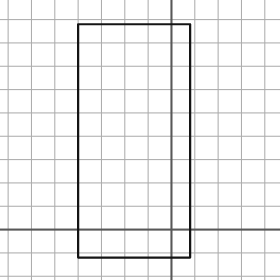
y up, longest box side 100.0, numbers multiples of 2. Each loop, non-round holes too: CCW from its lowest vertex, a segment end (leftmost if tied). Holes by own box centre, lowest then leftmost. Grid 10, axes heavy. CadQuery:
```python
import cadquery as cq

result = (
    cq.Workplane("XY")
    .moveTo(-40.0, -12.0)
    .lineTo(8.0, -12.0)
    .lineTo(8.0, 88.0)
    .lineTo(-40.0, 88.0)
    .close()
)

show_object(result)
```